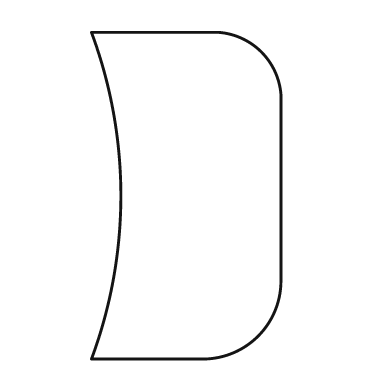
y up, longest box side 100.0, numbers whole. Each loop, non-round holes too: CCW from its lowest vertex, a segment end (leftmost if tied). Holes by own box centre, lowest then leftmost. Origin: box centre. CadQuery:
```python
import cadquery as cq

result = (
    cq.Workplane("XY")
    .moveTo(-29.0, -50.0)
    .lineTo(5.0, -50.0)
    .threePointArc((22.0, -43.0), (29.0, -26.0))
    .lineTo(29.0, 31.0)
    .threePointArc((23.0, 44.0), (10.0, 50.0))
    .lineTo(-29.0, 50.0)
    .threePointArc((-20.0, 0.0), (-29.0, -50.0))
    .close()
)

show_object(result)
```